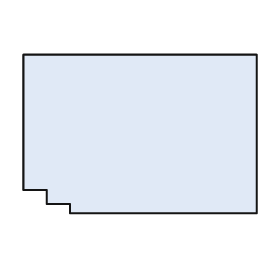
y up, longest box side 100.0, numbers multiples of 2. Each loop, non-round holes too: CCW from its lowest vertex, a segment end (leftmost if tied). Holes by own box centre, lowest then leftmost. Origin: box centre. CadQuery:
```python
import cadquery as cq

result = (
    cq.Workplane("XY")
    .moveTo(-30.0, -34.0)
    .lineTo(50.0, -34.0)
    .lineTo(50.0, 34.0)
    .lineTo(-50.0, 34.0)
    .lineTo(-50.0, -24.0)
    .lineTo(-40.0, -24.0)
    .lineTo(-40.0, -30.0)
    .lineTo(-30.0, -30.0)
    .close()
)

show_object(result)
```